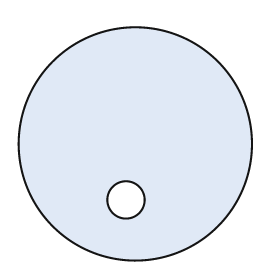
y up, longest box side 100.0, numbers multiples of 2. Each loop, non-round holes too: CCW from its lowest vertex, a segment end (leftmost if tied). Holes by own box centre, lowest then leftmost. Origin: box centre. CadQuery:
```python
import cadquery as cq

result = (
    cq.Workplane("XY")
    .moveTo(0.0, 0.0)
    .circle(50.0)
    .moveTo(-4.0, -24.0)
    .circle(8.0)
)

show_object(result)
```